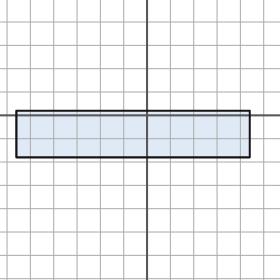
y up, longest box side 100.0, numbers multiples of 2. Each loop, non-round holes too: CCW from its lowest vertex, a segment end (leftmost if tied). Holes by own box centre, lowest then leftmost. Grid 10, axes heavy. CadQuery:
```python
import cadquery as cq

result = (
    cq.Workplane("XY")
    .moveTo(-56.0, -18.0)
    .lineTo(44.0, -18.0)
    .lineTo(44.0, 2.0)
    .lineTo(-56.0, 2.0)
    .close()
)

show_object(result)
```